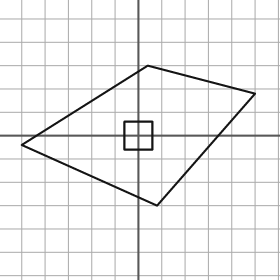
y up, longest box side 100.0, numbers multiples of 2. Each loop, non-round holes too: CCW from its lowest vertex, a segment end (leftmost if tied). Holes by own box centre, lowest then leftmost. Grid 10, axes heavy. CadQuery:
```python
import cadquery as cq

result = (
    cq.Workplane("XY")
    .moveTo(8.0, -30.0)
    .lineTo(50.0, 18.0)
    .lineTo(4.0, 30.0)
    .lineTo(-50.0, -4.0)
    .close()
    .moveTo(-6.0, -6.0)
    .lineTo(6.0, -6.0)
    .lineTo(6.0, 6.0)
    .lineTo(-6.0, 6.0)
    .close()
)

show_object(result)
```